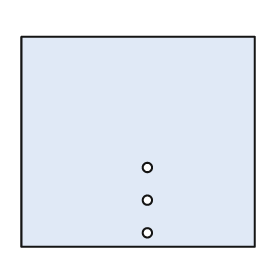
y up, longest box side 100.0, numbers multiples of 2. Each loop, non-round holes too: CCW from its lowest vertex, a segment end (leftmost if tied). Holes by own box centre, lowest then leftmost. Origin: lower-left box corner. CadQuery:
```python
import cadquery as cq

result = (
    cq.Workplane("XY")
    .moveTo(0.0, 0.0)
    .lineTo(100.0, 0.0)
    .lineTo(100.0, 90.0)
    .lineTo(0.0, 90.0)
    .close()
    .moveTo(54.0, 6.0)
    .circle(2.0)
    .moveTo(54.0, 20.0)
    .circle(2.0)
    .moveTo(54.0, 34.0)
    .circle(2.0)
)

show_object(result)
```